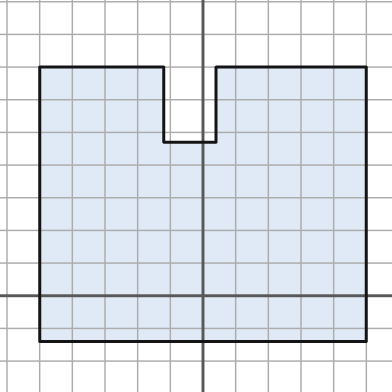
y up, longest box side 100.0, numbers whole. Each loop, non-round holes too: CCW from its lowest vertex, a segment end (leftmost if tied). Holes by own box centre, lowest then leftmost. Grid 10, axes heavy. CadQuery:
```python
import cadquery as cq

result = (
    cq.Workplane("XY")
    .moveTo(-50.0, -14.0)
    .lineTo(50.0, -14.0)
    .lineTo(50.0, 70.0)
    .lineTo(4.0, 70.0)
    .lineTo(4.0, 47.0)
    .lineTo(-12.0, 47.0)
    .lineTo(-12.0, 70.0)
    .lineTo(-50.0, 70.0)
    .close()
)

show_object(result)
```